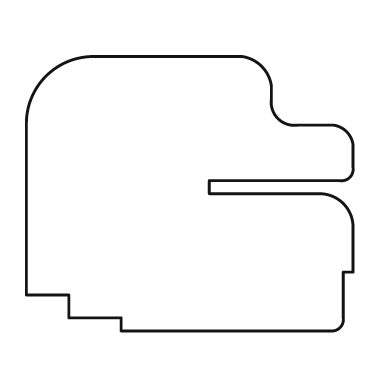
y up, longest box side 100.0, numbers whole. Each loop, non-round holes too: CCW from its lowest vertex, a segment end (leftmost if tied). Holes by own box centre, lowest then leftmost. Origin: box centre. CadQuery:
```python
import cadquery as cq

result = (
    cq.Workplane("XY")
    .moveTo(-21.0, -42.0)
    .lineTo(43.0, -42.0)
    .threePointArc((46.0, -41.0), (47.0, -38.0))
    .lineTo(47.0, -24.0)
    .lineTo(50.0, -24.0)
    .lineTo(50.0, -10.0)
    .threePointArc((47.0, -3.0), (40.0, 0.0))
    .lineTo(6.0, 0.0)
    .lineTo(6.0, 4.0)
    .lineTo(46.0, 4.0)
    .threePointArc((49.0, 5.0), (50.0, 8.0))
    .lineTo(50.0, 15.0)
    .threePointArc((48.0, 19.0), (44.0, 21.0))
    .lineTo(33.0, 21.0)
    .threePointArc((27.0, 23.0), (25.0, 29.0))
    .lineTo(25.0, 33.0)
    .threePointArc((22.0, 39.0), (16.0, 42.0))
    .lineTo(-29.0, 42.0)
    .threePointArc((-44.0, 36.0), (-50.0, 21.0))
    .lineTo(-50.0, -31.0)
    .lineTo(-37.0, -31.0)
    .lineTo(-37.0, -38.0)
    .lineTo(-21.0, -38.0)
    .close()
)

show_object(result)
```